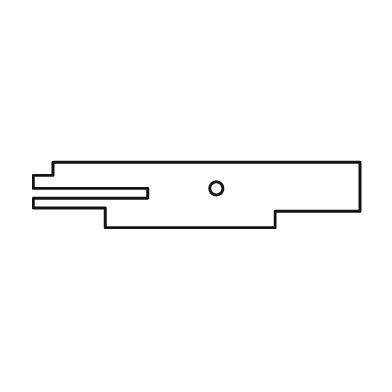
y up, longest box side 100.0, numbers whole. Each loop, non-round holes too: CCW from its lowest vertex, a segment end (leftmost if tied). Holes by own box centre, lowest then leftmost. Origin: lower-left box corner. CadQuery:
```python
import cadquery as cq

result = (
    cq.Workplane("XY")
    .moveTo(22.0, 0.0)
    .lineTo(74.0, 0.0)
    .lineTo(74.0, 5.0)
    .lineTo(100.0, 5.0)
    .lineTo(100.0, 20.0)
    .lineTo(6.0, 20.0)
    .lineTo(6.0, 16.0)
    .lineTo(0.0, 16.0)
    .lineTo(0.0, 12.0)
    .lineTo(35.0, 12.0)
    .lineTo(35.0, 9.0)
    .lineTo(0.0, 9.0)
    .lineTo(0.0, 6.0)
    .lineTo(22.0, 6.0)
    .close()
    .moveTo(56.0, 12.0)
    .circle(2.0)
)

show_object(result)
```